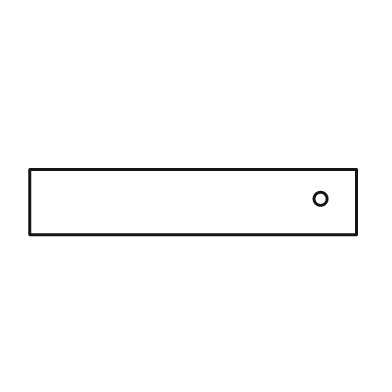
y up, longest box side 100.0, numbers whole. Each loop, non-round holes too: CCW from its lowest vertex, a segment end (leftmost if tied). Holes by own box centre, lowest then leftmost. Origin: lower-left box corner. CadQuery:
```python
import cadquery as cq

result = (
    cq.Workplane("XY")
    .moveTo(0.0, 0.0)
    .lineTo(100.0, 0.0)
    .lineTo(100.0, 20.0)
    .lineTo(0.0, 20.0)
    .close()
    .moveTo(89.0, 11.0)
    .circle(2.0)
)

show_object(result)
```